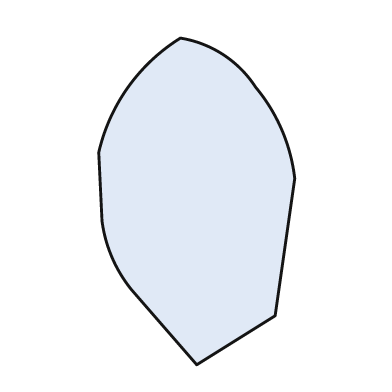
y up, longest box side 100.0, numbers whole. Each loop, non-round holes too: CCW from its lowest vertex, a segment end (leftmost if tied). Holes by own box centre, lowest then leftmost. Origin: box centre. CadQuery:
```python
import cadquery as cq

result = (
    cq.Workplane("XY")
    .moveTo(0.0, -50.0)
    .lineTo(24.0, -35.0)
    .lineTo(30.0, 7.0)
    .threePointArc((26.0, 22.0), (18.0, 35.0))
    .threePointArc((8.0, 45.0), (-5.0, 50.0))
    .threePointArc((-21.0, 35.0), (-30.0, 15.0))
    .lineTo(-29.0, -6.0)
    .threePointArc((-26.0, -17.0), (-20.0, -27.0))
    .close()
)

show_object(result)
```